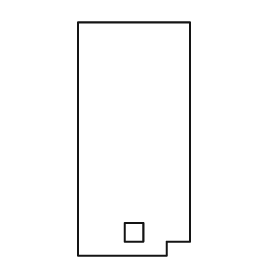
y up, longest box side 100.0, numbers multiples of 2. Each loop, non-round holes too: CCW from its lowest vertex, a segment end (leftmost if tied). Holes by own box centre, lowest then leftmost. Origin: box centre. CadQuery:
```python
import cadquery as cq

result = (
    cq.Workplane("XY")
    .moveTo(-24.0, -50.0)
    .lineTo(14.0, -50.0)
    .lineTo(14.0, -44.0)
    .lineTo(24.0, -44.0)
    .lineTo(24.0, 50.0)
    .lineTo(-24.0, 50.0)
    .close()
    .moveTo(-4.0, -44.0)
    .lineTo(4.0, -44.0)
    .lineTo(4.0, -36.0)
    .lineTo(-4.0, -36.0)
    .close()
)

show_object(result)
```